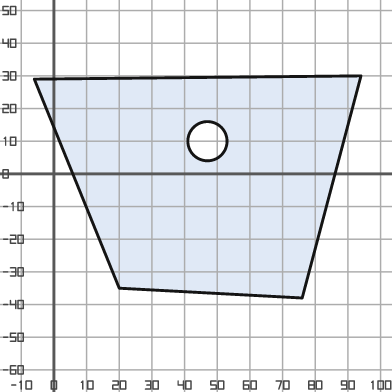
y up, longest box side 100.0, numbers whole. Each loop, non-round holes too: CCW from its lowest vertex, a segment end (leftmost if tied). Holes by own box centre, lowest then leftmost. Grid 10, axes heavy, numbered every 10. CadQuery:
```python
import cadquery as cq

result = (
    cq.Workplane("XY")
    .moveTo(76.0, -38.0)
    .lineTo(94.0, 30.0)
    .lineTo(-6.0, 29.0)
    .lineTo(20.0, -35.0)
    .close()
    .moveTo(47.0, 10.0)
    .circle(6.0)
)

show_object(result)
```